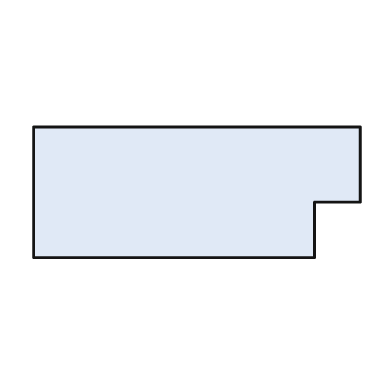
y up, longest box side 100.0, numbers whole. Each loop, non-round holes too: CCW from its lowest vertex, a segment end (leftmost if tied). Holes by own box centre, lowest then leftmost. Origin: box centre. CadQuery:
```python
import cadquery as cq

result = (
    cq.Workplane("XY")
    .moveTo(-50.0, -20.0)
    .lineTo(36.0, -20.0)
    .lineTo(36.0, -3.0)
    .lineTo(50.0, -3.0)
    .lineTo(50.0, 20.0)
    .lineTo(-50.0, 20.0)
    .close()
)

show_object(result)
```